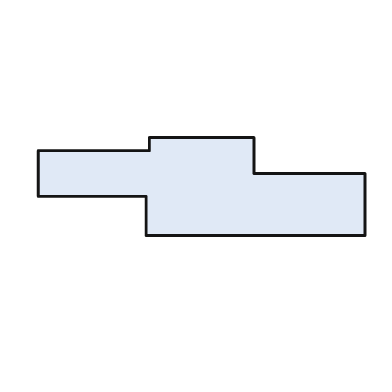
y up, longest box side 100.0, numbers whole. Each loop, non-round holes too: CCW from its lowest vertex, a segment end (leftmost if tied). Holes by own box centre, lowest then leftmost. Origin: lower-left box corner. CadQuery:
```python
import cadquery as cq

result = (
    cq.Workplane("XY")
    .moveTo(33.0, 0.0)
    .lineTo(100.0, 0.0)
    .lineTo(100.0, 19.0)
    .lineTo(66.0, 19.0)
    .lineTo(66.0, 30.0)
    .lineTo(34.0, 30.0)
    .lineTo(34.0, 26.0)
    .lineTo(0.0, 26.0)
    .lineTo(0.0, 12.0)
    .lineTo(33.0, 12.0)
    .close()
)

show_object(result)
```